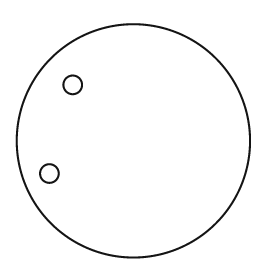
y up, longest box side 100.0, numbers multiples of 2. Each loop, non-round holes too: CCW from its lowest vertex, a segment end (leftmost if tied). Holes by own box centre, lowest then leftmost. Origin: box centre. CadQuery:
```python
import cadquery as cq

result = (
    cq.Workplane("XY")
    .moveTo(0.0, 0.0)
    .circle(50.0)
    .moveTo(-36.0, -14.0)
    .circle(4.0)
    .moveTo(-26.0, 24.0)
    .circle(4.0)
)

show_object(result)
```